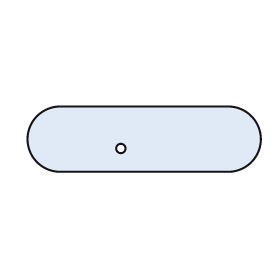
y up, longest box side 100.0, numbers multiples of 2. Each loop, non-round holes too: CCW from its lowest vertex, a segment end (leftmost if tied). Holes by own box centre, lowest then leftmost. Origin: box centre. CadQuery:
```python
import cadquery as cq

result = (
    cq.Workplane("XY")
    .moveTo(-36.0, -14.0)
    .lineTo(36.0, -14.0)
    .threePointArc((50.0, 0.0), (36.0, 14.0))
    .lineTo(-36.0, 14.0)
    .threePointArc((-50.0, 0.0), (-36.0, -14.0))
    .close()
    .moveTo(-10.0, -4.0)
    .circle(2.0)
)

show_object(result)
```